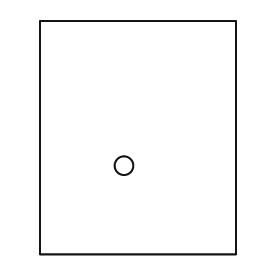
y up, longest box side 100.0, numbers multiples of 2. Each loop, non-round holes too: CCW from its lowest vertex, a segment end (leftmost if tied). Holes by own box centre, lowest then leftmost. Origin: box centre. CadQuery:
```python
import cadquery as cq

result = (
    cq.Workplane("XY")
    .moveTo(-42.0, -50.0)
    .lineTo(42.0, -50.0)
    .lineTo(42.0, 50.0)
    .lineTo(-42.0, 50.0)
    .close()
    .moveTo(-6.0, -12.0)
    .circle(4.0)
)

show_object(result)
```